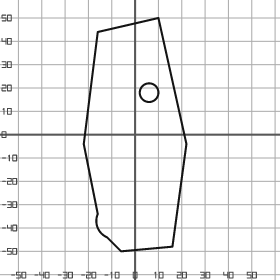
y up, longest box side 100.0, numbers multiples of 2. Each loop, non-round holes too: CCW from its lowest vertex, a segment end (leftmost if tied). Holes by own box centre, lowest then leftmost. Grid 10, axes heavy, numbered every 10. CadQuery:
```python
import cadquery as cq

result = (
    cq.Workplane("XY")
    .moveTo(-6.0, -50.0)
    .lineTo(16.0, -48.0)
    .lineTo(22.0, -4.0)
    .lineTo(10.0, 50.0)
    .lineTo(-16.0, 44.0)
    .lineTo(-22.0, -4.0)
    .lineTo(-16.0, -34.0)
    .threePointArc((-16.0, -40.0), (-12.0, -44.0))
    .close()
    .moveTo(6.0, 18.0)
    .circle(4.0)
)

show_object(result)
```